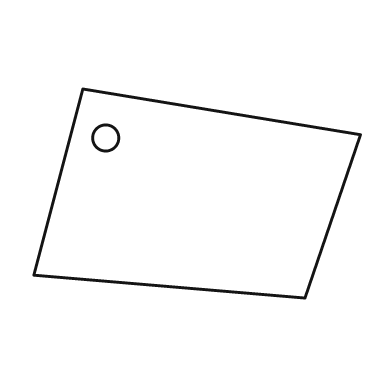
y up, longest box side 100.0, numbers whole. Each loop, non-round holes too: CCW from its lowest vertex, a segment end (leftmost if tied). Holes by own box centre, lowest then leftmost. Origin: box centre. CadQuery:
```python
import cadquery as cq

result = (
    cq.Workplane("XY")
    .moveTo(33.0, -32.0)
    .lineTo(50.0, 18.0)
    .lineTo(-35.0, 32.0)
    .lineTo(-50.0, -25.0)
    .close()
    .moveTo(-28.0, 17.0)
    .circle(4.0)
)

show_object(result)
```